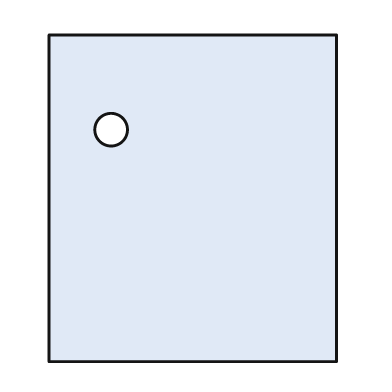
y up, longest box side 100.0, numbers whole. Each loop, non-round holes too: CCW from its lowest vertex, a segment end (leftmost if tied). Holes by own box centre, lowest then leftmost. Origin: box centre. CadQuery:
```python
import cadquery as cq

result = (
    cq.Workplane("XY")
    .moveTo(-44.0, -50.0)
    .lineTo(44.0, -50.0)
    .lineTo(44.0, 50.0)
    .lineTo(-44.0, 50.0)
    .close()
    .moveTo(-25.0, 21.0)
    .circle(5.0)
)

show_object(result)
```